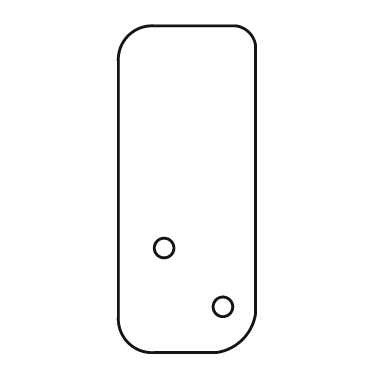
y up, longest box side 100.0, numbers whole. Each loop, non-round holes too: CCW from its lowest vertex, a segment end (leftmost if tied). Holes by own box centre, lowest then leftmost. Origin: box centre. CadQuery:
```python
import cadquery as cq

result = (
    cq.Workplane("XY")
    .moveTo(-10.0, -50.0)
    .lineTo(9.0, -50.0)
    .threePointArc((17.0, -46.0), (21.0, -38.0))
    .lineTo(21.0, 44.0)
    .threePointArc((19.0, 48.0), (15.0, 50.0))
    .lineTo(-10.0, 50.0)
    .threePointArc((-18.0, 47.0), (-21.0, 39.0))
    .lineTo(-21.0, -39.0)
    .threePointArc((-18.0, -47.0), (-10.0, -50.0))
    .close()
    .moveTo(11.0, -36.0)
    .circle(3.0)
    .moveTo(-7.0, -18.0)
    .circle(3.0)
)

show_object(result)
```